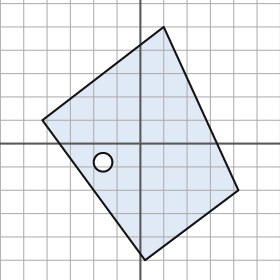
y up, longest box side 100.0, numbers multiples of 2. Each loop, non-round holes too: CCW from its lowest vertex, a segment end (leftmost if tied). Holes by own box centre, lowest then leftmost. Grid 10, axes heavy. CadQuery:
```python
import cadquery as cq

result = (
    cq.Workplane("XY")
    .moveTo(2.0, -50.0)
    .lineTo(42.0, -20.0)
    .lineTo(10.0, 50.0)
    .lineTo(-42.0, 10.0)
    .close()
    .moveTo(-16.0, -8.0)
    .circle(4.0)
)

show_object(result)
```